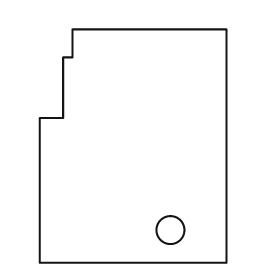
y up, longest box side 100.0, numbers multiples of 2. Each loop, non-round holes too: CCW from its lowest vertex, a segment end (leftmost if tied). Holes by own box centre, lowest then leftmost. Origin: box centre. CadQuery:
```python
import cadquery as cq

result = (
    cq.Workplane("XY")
    .moveTo(-40.0, -50.0)
    .lineTo(40.0, -50.0)
    .lineTo(40.0, 50.0)
    .lineTo(-26.0, 50.0)
    .lineTo(-26.0, 38.0)
    .lineTo(-30.0, 38.0)
    .lineTo(-30.0, 12.0)
    .lineTo(-40.0, 12.0)
    .close()
    .moveTo(16.0, -36.0)
    .circle(6.0)
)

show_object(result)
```